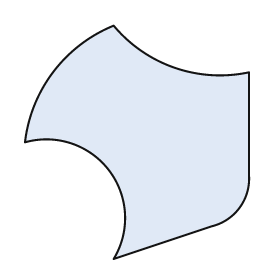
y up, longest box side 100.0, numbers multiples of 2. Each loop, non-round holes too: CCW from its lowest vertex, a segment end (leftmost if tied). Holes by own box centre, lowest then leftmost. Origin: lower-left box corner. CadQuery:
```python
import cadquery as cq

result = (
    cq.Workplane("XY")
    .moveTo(38.0, 0.0)
    .lineTo(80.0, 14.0)
    .threePointArc((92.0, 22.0), (96.0, 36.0))
    .lineTo(96.0, 80.0)
    .threePointArc((64.0, 82.0), (38.0, 100.0))
    .threePointArc((12.0, 80.0), (0.0, 50.0))
    .threePointArc((36.0, 38.0), (38.0, 0.0))
    .close()
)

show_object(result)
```